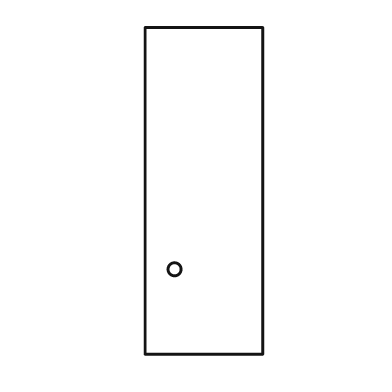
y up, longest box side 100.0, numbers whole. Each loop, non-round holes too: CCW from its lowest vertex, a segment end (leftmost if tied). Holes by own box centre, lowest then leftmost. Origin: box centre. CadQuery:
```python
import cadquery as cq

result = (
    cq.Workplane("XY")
    .moveTo(-18.0, -50.0)
    .lineTo(18.0, -50.0)
    .lineTo(18.0, 50.0)
    .lineTo(-18.0, 50.0)
    .close()
    .moveTo(-9.0, -24.0)
    .circle(2.0)
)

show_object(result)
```